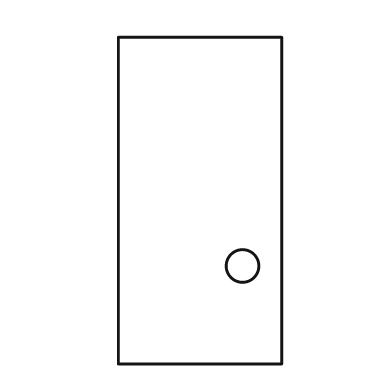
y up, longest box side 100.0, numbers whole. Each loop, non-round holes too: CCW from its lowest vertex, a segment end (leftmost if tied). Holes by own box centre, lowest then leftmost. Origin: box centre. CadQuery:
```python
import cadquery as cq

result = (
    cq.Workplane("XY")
    .moveTo(-25.0, -50.0)
    .lineTo(25.0, -50.0)
    .lineTo(25.0, 50.0)
    .lineTo(-25.0, 50.0)
    .close()
    .moveTo(13.0, -20.0)
    .circle(5.0)
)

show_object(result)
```